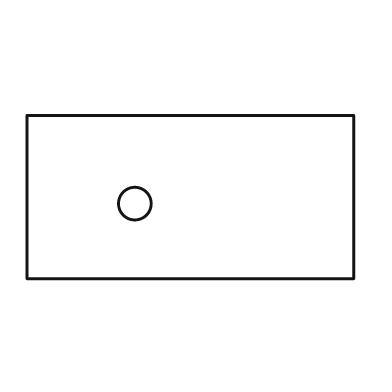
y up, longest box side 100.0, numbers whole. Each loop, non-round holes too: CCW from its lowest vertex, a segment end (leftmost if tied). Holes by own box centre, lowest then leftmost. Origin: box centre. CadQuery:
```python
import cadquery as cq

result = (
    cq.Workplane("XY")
    .moveTo(-50.0, -25.0)
    .lineTo(50.0, -25.0)
    .lineTo(50.0, 25.0)
    .lineTo(-50.0, 25.0)
    .close()
    .moveTo(-17.0, -2.0)
    .circle(5.0)
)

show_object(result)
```